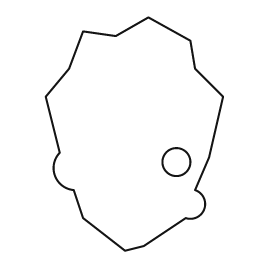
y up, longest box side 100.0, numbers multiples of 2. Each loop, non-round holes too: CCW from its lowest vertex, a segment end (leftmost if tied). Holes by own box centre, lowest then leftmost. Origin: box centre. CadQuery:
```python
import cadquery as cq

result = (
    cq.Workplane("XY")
    .moveTo(-4.0, -50.0)
    .lineTo(4.0, -48.0)
    .lineTo(22.0, -36.0)
    .threePointArc((30.0, -32.0), (26.0, -24.0))
    .lineTo(32.0, -10.0)
    .lineTo(38.0, 16.0)
    .lineTo(26.0, 28.0)
    .lineTo(24.0, 40.0)
    .lineTo(6.0, 50.0)
    .lineTo(-8.0, 42.0)
    .lineTo(-22.0, 44.0)
    .lineTo(-28.0, 28.0)
    .lineTo(-38.0, 16.0)
    .lineTo(-32.0, -8.0)
    .threePointArc((-34.0, -18.0), (-26.0, -24.0))
    .lineTo(-22.0, -36.0)
    .close()
    .moveTo(18.0, -12.0)
    .circle(6.0)
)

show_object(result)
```